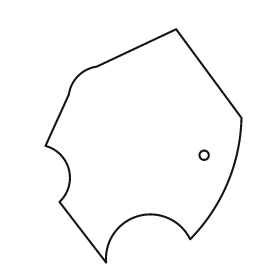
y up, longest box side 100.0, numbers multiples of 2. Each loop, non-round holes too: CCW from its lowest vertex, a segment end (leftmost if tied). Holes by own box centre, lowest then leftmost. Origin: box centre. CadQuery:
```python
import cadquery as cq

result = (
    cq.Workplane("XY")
    .moveTo(-16.0, -50.0)
    .threePointArc((-2.0, -30.0), (20.0, -40.0))
    .threePointArc((36.0, -16.0), (42.0, 12.0))
    .lineTo(14.0, 50.0)
    .lineTo(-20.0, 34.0)
    .threePointArc((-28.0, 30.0), (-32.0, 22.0))
    .lineTo(-42.0, 0.0)
    .threePointArc((-32.0, -10.0), (-36.0, -24.0))
    .close()
    .moveTo(26.0, -4.0)
    .circle(2.0)
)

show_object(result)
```